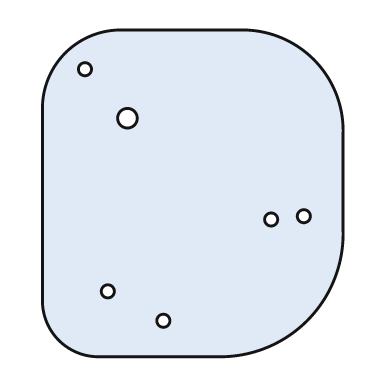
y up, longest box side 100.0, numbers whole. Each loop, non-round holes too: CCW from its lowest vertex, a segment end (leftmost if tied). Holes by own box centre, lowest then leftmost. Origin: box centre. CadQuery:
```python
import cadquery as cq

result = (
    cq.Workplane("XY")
    .moveTo(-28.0, -50.0)
    .lineTo(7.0, -50.0)
    .threePointArc((35.0, -39.0), (46.0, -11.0))
    .lineTo(46.0, 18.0)
    .threePointArc((37.0, 41.0), (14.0, 50.0))
    .lineTo(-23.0, 50.0)
    .threePointArc((-39.0, 43.0), (-46.0, 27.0))
    .lineTo(-46.0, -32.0)
    .threePointArc((-41.0, -45.0), (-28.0, -50.0))
    .close()
    .moveTo(-9.0, -39.0)
    .circle(2.0)
    .moveTo(-26.0, -30.0)
    .circle(2.0)
    .moveTo(24.0, -8.0)
    .circle(2.0)
    .moveTo(34.0, -7.0)
    .circle(2.0)
    .moveTo(-20.0, 23.0)
    .circle(3.0)
    .moveTo(-33.0, 38.0)
    .circle(2.0)
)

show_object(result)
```